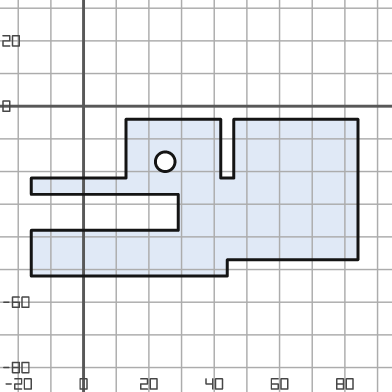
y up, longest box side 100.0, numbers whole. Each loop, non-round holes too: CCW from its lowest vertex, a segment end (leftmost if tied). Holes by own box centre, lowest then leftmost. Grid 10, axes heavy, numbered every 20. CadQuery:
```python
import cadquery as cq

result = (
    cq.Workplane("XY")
    .moveTo(-16.0, -52.0)
    .lineTo(44.0, -52.0)
    .lineTo(44.0, -47.0)
    .lineTo(84.0, -47.0)
    .lineTo(84.0, -4.0)
    .lineTo(46.0, -4.0)
    .lineTo(46.0, -22.0)
    .lineTo(42.0, -22.0)
    .lineTo(42.0, -4.0)
    .lineTo(13.0, -4.0)
    .lineTo(13.0, -22.0)
    .lineTo(-16.0, -22.0)
    .lineTo(-16.0, -27.0)
    .lineTo(29.0, -27.0)
    .lineTo(29.0, -38.0)
    .lineTo(-16.0, -38.0)
    .close()
    .moveTo(25.0, -17.0)
    .circle(3.0)
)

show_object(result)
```